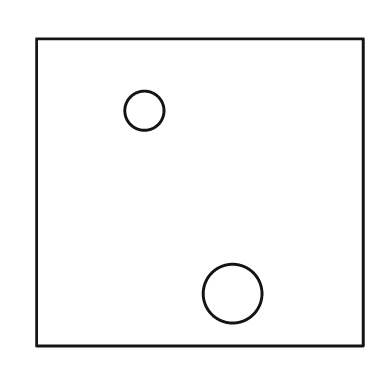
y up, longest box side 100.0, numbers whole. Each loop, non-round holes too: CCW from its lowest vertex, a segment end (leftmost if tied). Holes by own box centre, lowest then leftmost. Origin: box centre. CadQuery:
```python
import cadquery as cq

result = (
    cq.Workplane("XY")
    .moveTo(-50.0, -47.0)
    .lineTo(50.0, -47.0)
    .lineTo(50.0, 47.0)
    .lineTo(-50.0, 47.0)
    .close()
    .moveTo(10.0, -31.0)
    .circle(9.0)
    .moveTo(-17.0, 25.0)
    .circle(6.0)
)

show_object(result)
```